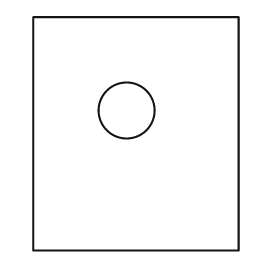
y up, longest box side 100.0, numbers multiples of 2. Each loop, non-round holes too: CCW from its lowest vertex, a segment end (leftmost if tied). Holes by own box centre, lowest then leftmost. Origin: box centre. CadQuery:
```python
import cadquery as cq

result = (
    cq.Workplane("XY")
    .moveTo(-44.0, -50.0)
    .lineTo(44.0, -50.0)
    .lineTo(44.0, 50.0)
    .lineTo(-44.0, 50.0)
    .close()
    .moveTo(-4.0, 10.0)
    .circle(12.0)
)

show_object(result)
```